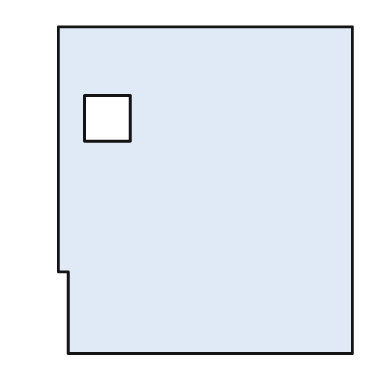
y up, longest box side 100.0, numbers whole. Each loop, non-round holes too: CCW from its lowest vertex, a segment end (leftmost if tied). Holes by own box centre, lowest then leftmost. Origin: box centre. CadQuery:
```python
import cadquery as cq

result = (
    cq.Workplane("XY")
    .moveTo(-42.0, -50.0)
    .lineTo(45.0, -50.0)
    .lineTo(45.0, 50.0)
    .lineTo(-45.0, 50.0)
    .lineTo(-45.0, -25.0)
    .lineTo(-42.0, -25.0)
    .close()
    .moveTo(-37.0, 15.0)
    .lineTo(-23.0, 15.0)
    .lineTo(-23.0, 29.0)
    .lineTo(-37.0, 29.0)
    .close()
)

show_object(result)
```